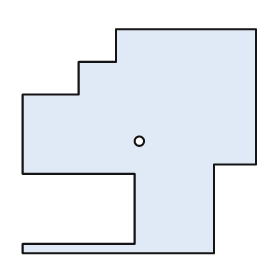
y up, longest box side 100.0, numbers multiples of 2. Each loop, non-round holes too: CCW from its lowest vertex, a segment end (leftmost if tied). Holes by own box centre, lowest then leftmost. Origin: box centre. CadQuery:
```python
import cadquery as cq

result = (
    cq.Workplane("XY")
    .moveTo(-50.0, -48.0)
    .lineTo(32.0, -48.0)
    .lineTo(32.0, -10.0)
    .lineTo(50.0, -10.0)
    .lineTo(50.0, 48.0)
    .lineTo(-10.0, 48.0)
    .lineTo(-10.0, 34.0)
    .lineTo(-26.0, 34.0)
    .lineTo(-26.0, 20.0)
    .lineTo(-50.0, 20.0)
    .lineTo(-50.0, -14.0)
    .lineTo(-2.0, -14.0)
    .lineTo(-2.0, -44.0)
    .lineTo(-50.0, -44.0)
    .close()
    .moveTo(0.0, 0.0)
    .circle(2.0)
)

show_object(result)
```